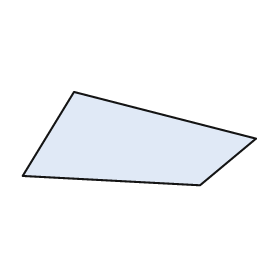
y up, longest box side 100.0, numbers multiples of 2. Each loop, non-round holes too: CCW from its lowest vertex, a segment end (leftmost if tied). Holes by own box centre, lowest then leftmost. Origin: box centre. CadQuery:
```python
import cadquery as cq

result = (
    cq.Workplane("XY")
    .moveTo(26.0, -20.0)
    .lineTo(50.0, 0.0)
    .lineTo(-28.0, 20.0)
    .lineTo(-50.0, -16.0)
    .close()
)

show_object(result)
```